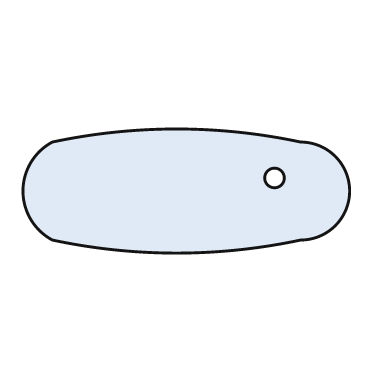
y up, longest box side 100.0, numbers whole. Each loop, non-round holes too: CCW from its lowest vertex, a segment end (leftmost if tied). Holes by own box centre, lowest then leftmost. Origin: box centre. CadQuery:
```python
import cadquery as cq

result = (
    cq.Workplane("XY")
    .moveTo(-41.0, -15.0)
    .threePointArc((-3.0, -19.0), (35.0, -15.0))
    .threePointArc((50.0, 0.0), (35.0, 15.0))
    .threePointArc((-3.0, 19.0), (-41.0, 15.0))
    .threePointArc((-50.0, 0.0), (-41.0, -15.0))
    .close()
    .moveTo(27.0, 4.0)
    .circle(3.0)
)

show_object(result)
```